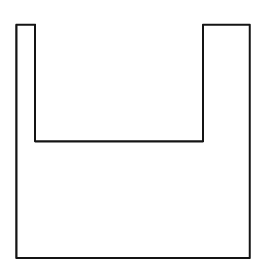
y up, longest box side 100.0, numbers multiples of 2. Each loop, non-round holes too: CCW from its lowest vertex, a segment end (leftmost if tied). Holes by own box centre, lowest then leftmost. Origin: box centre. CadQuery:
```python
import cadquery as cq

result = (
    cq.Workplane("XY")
    .moveTo(-50.0, -50.0)
    .lineTo(50.0, -50.0)
    .lineTo(50.0, 50.0)
    .lineTo(30.0, 50.0)
    .lineTo(30.0, 0.0)
    .lineTo(-42.0, 0.0)
    .lineTo(-42.0, 50.0)
    .lineTo(-50.0, 50.0)
    .close()
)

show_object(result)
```